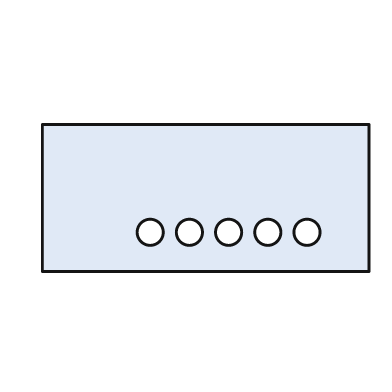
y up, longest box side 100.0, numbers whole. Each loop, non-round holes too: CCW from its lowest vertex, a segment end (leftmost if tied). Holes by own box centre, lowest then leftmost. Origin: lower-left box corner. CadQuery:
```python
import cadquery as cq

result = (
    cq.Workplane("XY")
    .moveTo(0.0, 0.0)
    .lineTo(100.0, 0.0)
    .lineTo(100.0, 45.0)
    .lineTo(0.0, 45.0)
    .close()
    .moveTo(33.0, 12.0)
    .circle(4.0)
    .moveTo(45.0, 12.0)
    .circle(4.0)
    .moveTo(57.0, 12.0)
    .circle(4.0)
    .moveTo(69.0, 12.0)
    .circle(4.0)
    .moveTo(81.0, 12.0)
    .circle(4.0)
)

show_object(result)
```